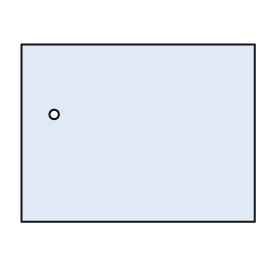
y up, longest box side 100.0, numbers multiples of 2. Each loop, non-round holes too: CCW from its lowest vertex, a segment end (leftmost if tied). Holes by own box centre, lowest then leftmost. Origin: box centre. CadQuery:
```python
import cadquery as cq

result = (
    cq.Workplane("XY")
    .moveTo(-50.0, -38.0)
    .lineTo(50.0, -38.0)
    .lineTo(50.0, 38.0)
    .lineTo(-50.0, 38.0)
    .close()
    .moveTo(-36.0, 8.0)
    .circle(2.0)
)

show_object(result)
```